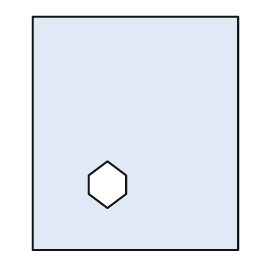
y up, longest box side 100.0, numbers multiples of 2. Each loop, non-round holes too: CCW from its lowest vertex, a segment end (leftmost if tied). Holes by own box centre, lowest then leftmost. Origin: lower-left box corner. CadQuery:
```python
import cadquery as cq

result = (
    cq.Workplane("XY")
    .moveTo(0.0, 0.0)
    .lineTo(88.0, 0.0)
    .lineTo(88.0, 100.0)
    .lineTo(0.0, 100.0)
    .close()
    .moveTo(32.0, 18.0)
    .lineTo(40.0, 24.0)
    .lineTo(40.0, 32.0)
    .lineTo(32.0, 38.0)
    .lineTo(24.0, 32.0)
    .lineTo(24.0, 24.0)
    .close()
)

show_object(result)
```